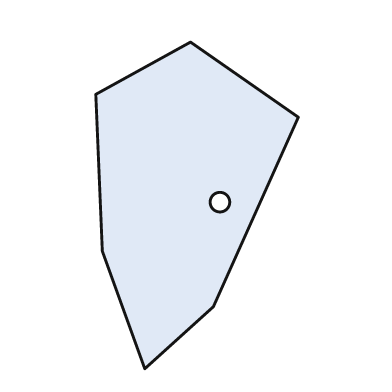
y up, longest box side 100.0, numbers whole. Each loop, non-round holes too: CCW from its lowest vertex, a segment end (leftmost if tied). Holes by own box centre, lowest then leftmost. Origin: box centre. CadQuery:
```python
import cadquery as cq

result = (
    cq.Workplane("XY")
    .moveTo(-16.0, -50.0)
    .lineTo(5.0, -31.0)
    .lineTo(31.0, 27.0)
    .lineTo(-2.0, 50.0)
    .lineTo(-31.0, 34.0)
    .lineTo(-29.0, -14.0)
    .close()
    .moveTo(7.0, 1.0)
    .circle(3.0)
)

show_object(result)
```